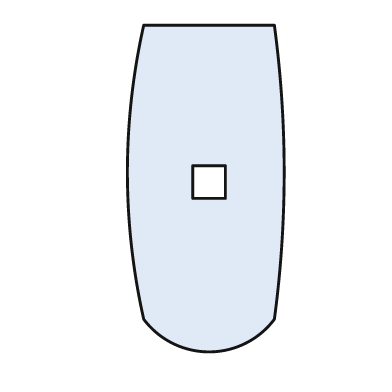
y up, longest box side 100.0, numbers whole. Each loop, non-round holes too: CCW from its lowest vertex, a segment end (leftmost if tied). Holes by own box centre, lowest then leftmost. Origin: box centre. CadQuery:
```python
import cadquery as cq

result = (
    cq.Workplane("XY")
    .moveTo(-19.0, -40.0)
    .threePointArc((1.0, -50.0), (21.0, -40.0))
    .threePointArc((24.0, 5.0), (21.0, 50.0))
    .lineTo(-19.0, 50.0)
    .threePointArc((-24.0, 5.0), (-19.0, -40.0))
    .close()
    .moveTo(-4.0, -3.0)
    .lineTo(6.0, -3.0)
    .lineTo(6.0, 7.0)
    .lineTo(-4.0, 7.0)
    .close()
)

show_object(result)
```